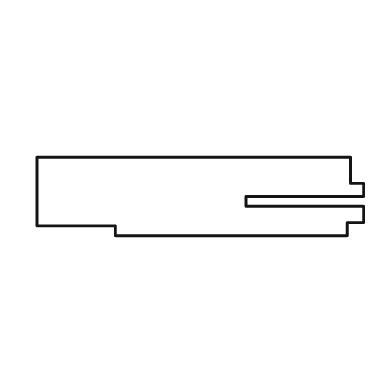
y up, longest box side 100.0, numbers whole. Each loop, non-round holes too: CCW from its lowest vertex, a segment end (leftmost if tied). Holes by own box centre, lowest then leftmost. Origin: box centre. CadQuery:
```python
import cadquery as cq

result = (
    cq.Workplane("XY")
    .moveTo(-26.0, -12.0)
    .lineTo(45.0, -12.0)
    .lineTo(45.0, -8.0)
    .lineTo(50.0, -8.0)
    .lineTo(50.0, -3.0)
    .lineTo(14.0, -3.0)
    .lineTo(14.0, 0.0)
    .lineTo(50.0, 0.0)
    .lineTo(50.0, 4.0)
    .lineTo(46.0, 4.0)
    .lineTo(46.0, 12.0)
    .lineTo(-50.0, 12.0)
    .lineTo(-50.0, -9.0)
    .lineTo(-26.0, -9.0)
    .close()
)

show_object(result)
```